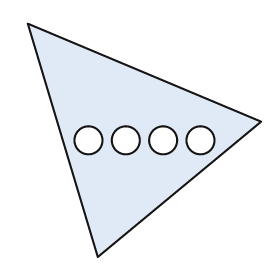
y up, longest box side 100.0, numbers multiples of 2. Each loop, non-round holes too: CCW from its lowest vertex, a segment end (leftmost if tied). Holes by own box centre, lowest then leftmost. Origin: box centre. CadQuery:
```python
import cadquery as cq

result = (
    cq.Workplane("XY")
    .moveTo(-20.0, -50.0)
    .lineTo(50.0, 8.0)
    .lineTo(-50.0, 50.0)
    .close()
    .moveTo(-24.0, 0.0)
    .circle(6.0)
    .moveTo(-8.0, 0.0)
    .circle(6.0)
    .moveTo(8.0, 0.0)
    .circle(6.0)
    .moveTo(24.0, 0.0)
    .circle(6.0)
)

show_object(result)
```